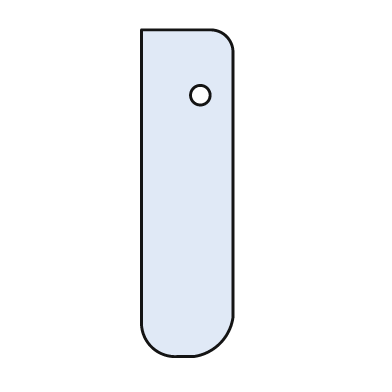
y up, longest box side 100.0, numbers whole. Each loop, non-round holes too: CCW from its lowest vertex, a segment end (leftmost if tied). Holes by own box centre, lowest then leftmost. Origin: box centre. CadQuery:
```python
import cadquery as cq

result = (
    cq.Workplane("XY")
    .moveTo(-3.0, -50.0)
    .lineTo(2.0, -50.0)
    .threePointArc((10.0, -46.0), (14.0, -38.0))
    .lineTo(14.0, 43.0)
    .threePointArc((12.0, 48.0), (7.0, 50.0))
    .lineTo(-14.0, 50.0)
    .lineTo(-14.0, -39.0)
    .threePointArc((-11.0, -47.0), (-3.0, -50.0))
    .close()
    .moveTo(4.0, 30.0)
    .circle(3.0)
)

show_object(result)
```